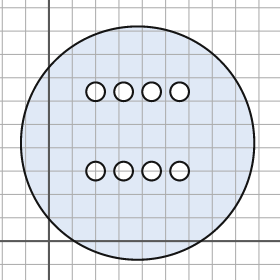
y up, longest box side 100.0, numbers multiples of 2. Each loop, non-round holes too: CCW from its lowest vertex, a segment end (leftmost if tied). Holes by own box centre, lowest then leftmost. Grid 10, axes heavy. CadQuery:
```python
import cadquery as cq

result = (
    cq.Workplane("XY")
    .moveTo(38.0, 42.0)
    .circle(50.0)
    .moveTo(20.0, 30.0)
    .circle(4.0)
    .moveTo(32.0, 30.0)
    .circle(4.0)
    .moveTo(44.0, 30.0)
    .circle(4.0)
    .moveTo(56.0, 30.0)
    .circle(4.0)
    .moveTo(20.0, 64.0)
    .circle(4.0)
    .moveTo(32.0, 64.0)
    .circle(4.0)
    .moveTo(44.0, 64.0)
    .circle(4.0)
    .moveTo(56.0, 64.0)
    .circle(4.0)
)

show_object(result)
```